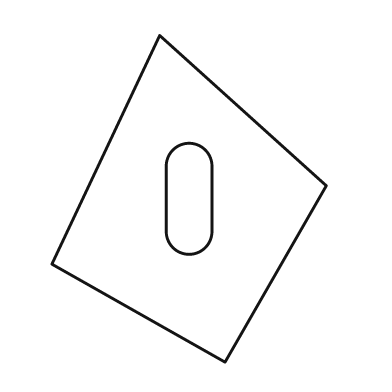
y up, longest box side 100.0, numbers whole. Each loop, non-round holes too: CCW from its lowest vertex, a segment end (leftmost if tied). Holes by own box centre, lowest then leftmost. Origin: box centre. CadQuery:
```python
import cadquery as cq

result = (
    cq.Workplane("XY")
    .moveTo(11.0, -50.0)
    .lineTo(42.0, 4.0)
    .lineTo(-9.0, 50.0)
    .lineTo(-42.0, -20.0)
    .close()
    .moveTo(-7.0, -10.0)
    .threePointArc((0.0, -17.0), (7.0, -10.0))
    .lineTo(7.0, 10.0)
    .threePointArc((0.0, 17.0), (-7.0, 10.0))
    .close()
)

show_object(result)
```